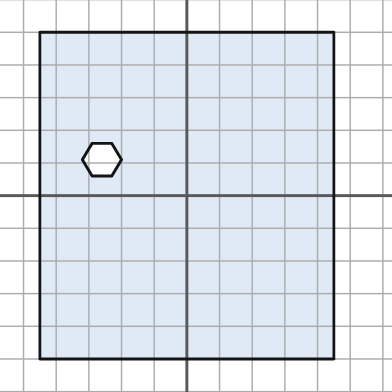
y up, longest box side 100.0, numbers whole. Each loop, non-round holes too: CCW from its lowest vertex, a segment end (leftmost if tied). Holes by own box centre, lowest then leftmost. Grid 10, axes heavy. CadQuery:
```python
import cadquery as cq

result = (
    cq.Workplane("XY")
    .moveTo(-45.0, -50.0)
    .lineTo(45.0, -50.0)
    .lineTo(45.0, 50.0)
    .lineTo(-45.0, 50.0)
    .close()
    .moveTo(-29.0, 6.0)
    .lineTo(-23.0, 6.0)
    .lineTo(-20.0, 11.0)
    .lineTo(-23.0, 16.0)
    .lineTo(-29.0, 16.0)
    .lineTo(-32.0, 11.0)
    .close()
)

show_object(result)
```